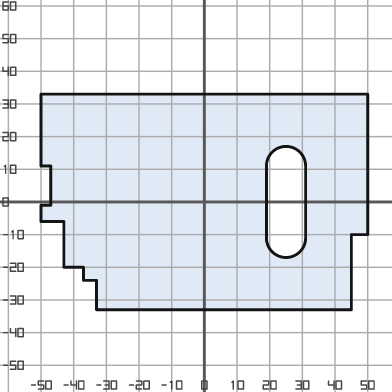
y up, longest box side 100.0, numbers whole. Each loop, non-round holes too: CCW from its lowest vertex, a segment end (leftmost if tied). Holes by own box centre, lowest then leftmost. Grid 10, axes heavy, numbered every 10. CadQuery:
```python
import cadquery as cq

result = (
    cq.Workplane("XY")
    .moveTo(-33.0, -33.0)
    .lineTo(45.0, -33.0)
    .lineTo(45.0, -10.0)
    .lineTo(50.0, -10.0)
    .lineTo(50.0, 33.0)
    .lineTo(-50.0, 33.0)
    .lineTo(-50.0, 11.0)
    .lineTo(-47.0, 11.0)
    .lineTo(-47.0, -1.0)
    .lineTo(-50.0, -1.0)
    .lineTo(-50.0, -6.0)
    .lineTo(-43.0, -6.0)
    .lineTo(-43.0, -20.0)
    .lineTo(-37.0, -20.0)
    .lineTo(-37.0, -24.0)
    .lineTo(-33.0, -24.0)
    .close()
    .moveTo(19.0, -11.0)
    .threePointArc((25.0, -17.0), (31.0, -11.0))
    .lineTo(31.0, 11.0)
    .threePointArc((25.0, 17.0), (19.0, 11.0))
    .close()
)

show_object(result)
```